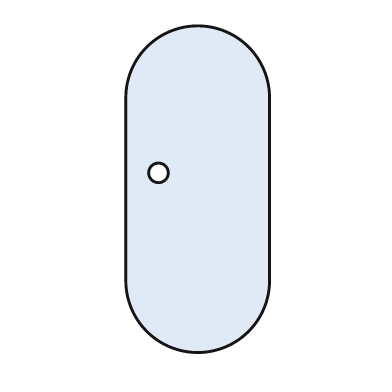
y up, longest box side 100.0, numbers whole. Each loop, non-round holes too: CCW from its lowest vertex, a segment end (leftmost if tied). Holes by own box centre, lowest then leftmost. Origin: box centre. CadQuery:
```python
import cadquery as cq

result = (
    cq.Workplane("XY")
    .moveTo(-22.0, -28.0)
    .threePointArc((0.0, -50.0), (22.0, -28.0))
    .lineTo(22.0, 28.0)
    .threePointArc((0.0, 50.0), (-22.0, 28.0))
    .close()
    .moveTo(-12.0, 5.0)
    .circle(3.0)
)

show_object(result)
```